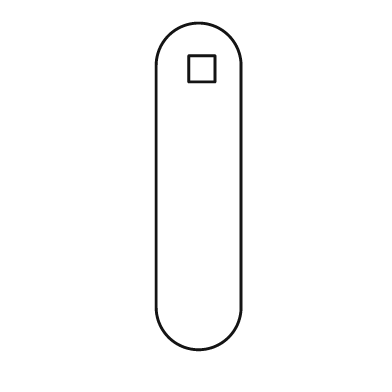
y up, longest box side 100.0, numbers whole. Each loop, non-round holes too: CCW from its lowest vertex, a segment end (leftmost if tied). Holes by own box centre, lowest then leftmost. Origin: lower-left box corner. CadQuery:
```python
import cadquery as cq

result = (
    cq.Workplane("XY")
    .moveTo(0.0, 13.0)
    .threePointArc((13.0, 0.0), (26.0, 13.0))
    .lineTo(26.0, 87.0)
    .threePointArc((13.0, 100.0), (0.0, 87.0))
    .close()
    .moveTo(10.0, 82.0)
    .lineTo(18.0, 82.0)
    .lineTo(18.0, 90.0)
    .lineTo(10.0, 90.0)
    .close()
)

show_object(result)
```